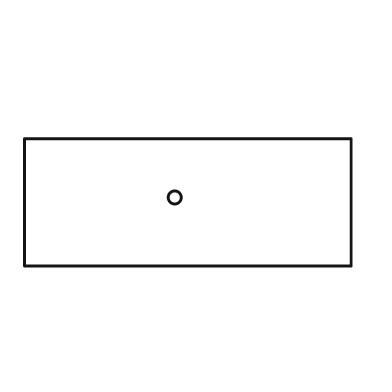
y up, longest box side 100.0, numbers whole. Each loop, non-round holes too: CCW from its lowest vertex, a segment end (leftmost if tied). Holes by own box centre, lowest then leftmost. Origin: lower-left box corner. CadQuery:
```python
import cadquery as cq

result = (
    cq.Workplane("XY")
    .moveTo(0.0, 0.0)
    .lineTo(100.0, 0.0)
    .lineTo(100.0, 39.0)
    .lineTo(0.0, 39.0)
    .close()
    .moveTo(46.0, 21.0)
    .circle(2.0)
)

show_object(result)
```